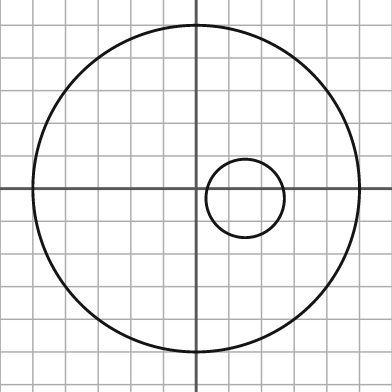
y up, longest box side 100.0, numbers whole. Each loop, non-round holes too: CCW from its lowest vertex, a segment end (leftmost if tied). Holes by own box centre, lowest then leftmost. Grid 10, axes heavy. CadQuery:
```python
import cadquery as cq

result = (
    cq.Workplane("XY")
    .moveTo(0.0, 0.0)
    .circle(50.0)
    .moveTo(15.0, -3.0)
    .circle(12.0)
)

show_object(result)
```